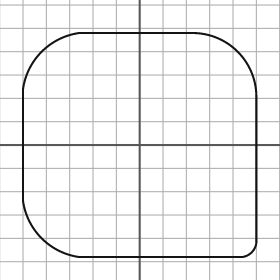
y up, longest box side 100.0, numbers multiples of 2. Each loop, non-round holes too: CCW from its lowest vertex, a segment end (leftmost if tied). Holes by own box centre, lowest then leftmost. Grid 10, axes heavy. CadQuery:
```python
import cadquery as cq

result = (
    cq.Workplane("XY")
    .moveTo(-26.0, -48.0)
    .lineTo(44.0, -48.0)
    .threePointArc((48.0, -46.0), (50.0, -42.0))
    .lineTo(50.0, 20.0)
    .threePointArc((42.0, 40.0), (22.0, 48.0))
    .lineTo(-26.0, 48.0)
    .threePointArc((-42.0, 40.0), (-50.0, 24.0))
    .lineTo(-50.0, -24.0)
    .threePointArc((-42.0, -40.0), (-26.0, -48.0))
    .close()
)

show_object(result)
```